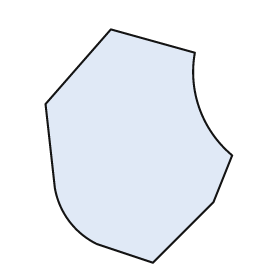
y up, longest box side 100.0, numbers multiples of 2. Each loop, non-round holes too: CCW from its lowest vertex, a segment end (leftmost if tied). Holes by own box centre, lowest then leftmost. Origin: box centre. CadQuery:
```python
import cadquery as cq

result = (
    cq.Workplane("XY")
    .moveTo(6.0, -50.0)
    .lineTo(32.0, -24.0)
    .lineTo(40.0, -4.0)
    .threePointArc((26.0, 16.0), (24.0, 40.0))
    .lineTo(-12.0, 50.0)
    .lineTo(-40.0, 18.0)
    .lineTo(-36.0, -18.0)
    .threePointArc((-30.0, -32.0), (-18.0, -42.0))
    .close()
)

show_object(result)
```